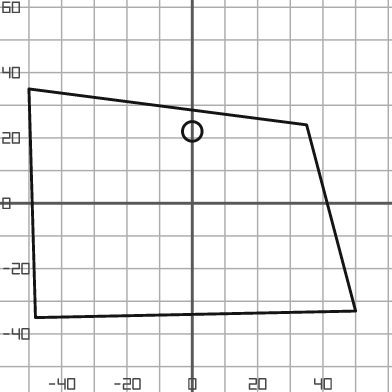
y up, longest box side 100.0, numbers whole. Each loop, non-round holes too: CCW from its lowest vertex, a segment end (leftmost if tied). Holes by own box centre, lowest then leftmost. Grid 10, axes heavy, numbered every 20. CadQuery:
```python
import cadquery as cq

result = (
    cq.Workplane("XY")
    .moveTo(-48.0, -35.0)
    .lineTo(50.0, -33.0)
    .lineTo(35.0, 24.0)
    .lineTo(-50.0, 35.0)
    .close()
    .moveTo(0.0, 22.0)
    .circle(3.0)
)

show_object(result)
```